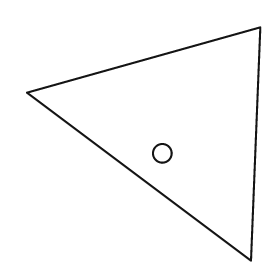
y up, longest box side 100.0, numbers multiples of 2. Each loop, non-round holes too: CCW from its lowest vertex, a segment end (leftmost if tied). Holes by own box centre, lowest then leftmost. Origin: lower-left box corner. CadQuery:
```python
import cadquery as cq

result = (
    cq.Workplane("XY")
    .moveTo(96.0, 0.0)
    .lineTo(100.0, 100.0)
    .lineTo(0.0, 72.0)
    .close()
    .moveTo(58.0, 46.0)
    .circle(4.0)
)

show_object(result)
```